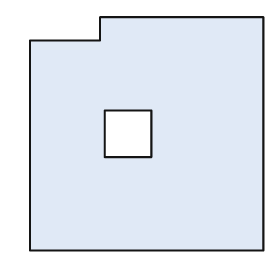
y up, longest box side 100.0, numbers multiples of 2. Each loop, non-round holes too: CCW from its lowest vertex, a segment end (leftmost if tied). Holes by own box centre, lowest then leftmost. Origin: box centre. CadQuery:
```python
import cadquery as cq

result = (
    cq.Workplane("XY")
    .moveTo(-50.0, -50.0)
    .lineTo(50.0, -50.0)
    .lineTo(50.0, 50.0)
    .lineTo(-20.0, 50.0)
    .lineTo(-20.0, 40.0)
    .lineTo(-50.0, 40.0)
    .close()
    .moveTo(-18.0, -10.0)
    .lineTo(2.0, -10.0)
    .lineTo(2.0, 10.0)
    .lineTo(-18.0, 10.0)
    .close()
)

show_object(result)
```